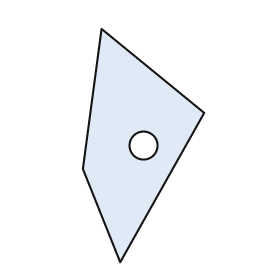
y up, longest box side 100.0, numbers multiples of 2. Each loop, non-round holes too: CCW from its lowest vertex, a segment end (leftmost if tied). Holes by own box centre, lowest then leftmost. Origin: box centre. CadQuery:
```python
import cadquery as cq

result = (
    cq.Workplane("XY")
    .moveTo(-10.0, -50.0)
    .lineTo(26.0, 14.0)
    .lineTo(-18.0, 50.0)
    .lineTo(-26.0, -10.0)
    .close()
    .moveTo(0.0, 0.0)
    .circle(6.0)
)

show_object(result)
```